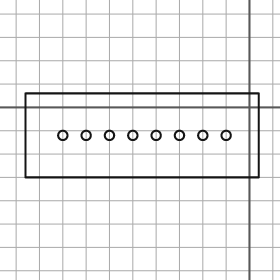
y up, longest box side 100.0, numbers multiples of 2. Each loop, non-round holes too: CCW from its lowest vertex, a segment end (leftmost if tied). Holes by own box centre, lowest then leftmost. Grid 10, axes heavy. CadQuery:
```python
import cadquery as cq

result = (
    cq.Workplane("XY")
    .moveTo(-96.0, -30.0)
    .lineTo(4.0, -30.0)
    .lineTo(4.0, 6.0)
    .lineTo(-96.0, 6.0)
    .close()
    .moveTo(-80.0, -12.0)
    .circle(2.0)
    .moveTo(-70.0, -12.0)
    .circle(2.0)
    .moveTo(-60.0, -12.0)
    .circle(2.0)
    .moveTo(-50.0, -12.0)
    .circle(2.0)
    .moveTo(-40.0, -12.0)
    .circle(2.0)
    .moveTo(-30.0, -12.0)
    .circle(2.0)
    .moveTo(-20.0, -12.0)
    .circle(2.0)
    .moveTo(-10.0, -12.0)
    .circle(2.0)
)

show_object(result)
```